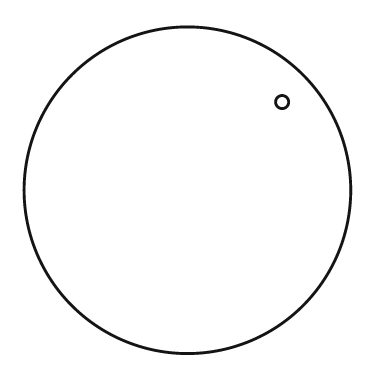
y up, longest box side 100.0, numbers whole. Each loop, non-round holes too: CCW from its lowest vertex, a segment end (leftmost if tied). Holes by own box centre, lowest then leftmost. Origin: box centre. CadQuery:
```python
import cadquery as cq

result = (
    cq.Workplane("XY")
    .moveTo(0.0, 0.0)
    .circle(50.0)
    .moveTo(29.0, 27.0)
    .circle(2.0)
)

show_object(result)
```